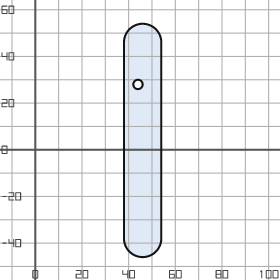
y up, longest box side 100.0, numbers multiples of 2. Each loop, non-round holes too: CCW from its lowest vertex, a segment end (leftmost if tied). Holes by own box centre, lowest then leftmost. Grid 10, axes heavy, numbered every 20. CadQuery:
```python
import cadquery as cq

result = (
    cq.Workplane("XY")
    .moveTo(38.0, -38.0)
    .threePointArc((46.0, -46.0), (54.0, -38.0))
    .lineTo(54.0, 46.0)
    .threePointArc((46.0, 54.0), (38.0, 46.0))
    .close()
    .moveTo(44.0, 28.0)
    .circle(2.0)
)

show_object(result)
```